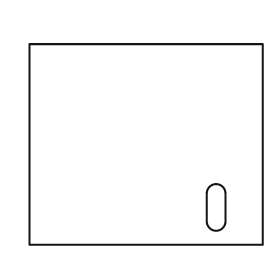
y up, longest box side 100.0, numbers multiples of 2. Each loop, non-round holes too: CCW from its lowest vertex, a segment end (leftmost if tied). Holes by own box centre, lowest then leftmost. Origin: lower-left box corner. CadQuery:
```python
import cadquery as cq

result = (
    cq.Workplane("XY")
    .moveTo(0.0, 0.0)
    .lineTo(100.0, 0.0)
    .lineTo(100.0, 86.0)
    .lineTo(0.0, 86.0)
    .close()
    .moveTo(76.0, 10.0)
    .threePointArc((80.0, 6.0), (84.0, 10.0))
    .lineTo(84.0, 22.0)
    .threePointArc((80.0, 26.0), (76.0, 22.0))
    .close()
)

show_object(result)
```